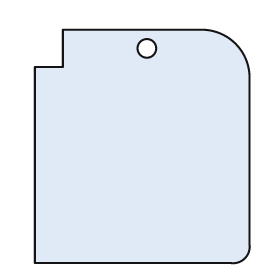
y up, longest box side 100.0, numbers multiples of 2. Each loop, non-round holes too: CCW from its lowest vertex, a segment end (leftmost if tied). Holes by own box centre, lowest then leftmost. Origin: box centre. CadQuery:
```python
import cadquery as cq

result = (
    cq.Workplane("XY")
    .moveTo(-46.0, -50.0)
    .lineTo(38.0, -50.0)
    .threePointArc((44.0, -48.0), (46.0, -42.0))
    .lineTo(46.0, 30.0)
    .threePointArc((40.0, 44.0), (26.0, 50.0))
    .lineTo(-34.0, 50.0)
    .lineTo(-34.0, 34.0)
    .lineTo(-46.0, 34.0)
    .close()
    .moveTo(2.0, 42.0)
    .circle(4.0)
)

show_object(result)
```